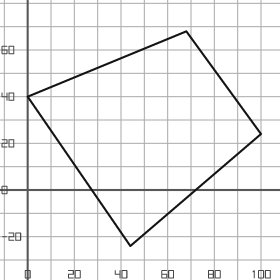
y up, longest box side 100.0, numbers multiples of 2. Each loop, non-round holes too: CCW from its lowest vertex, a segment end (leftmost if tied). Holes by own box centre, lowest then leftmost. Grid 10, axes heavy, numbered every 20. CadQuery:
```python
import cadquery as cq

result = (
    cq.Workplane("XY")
    .moveTo(44.0, -24.0)
    .lineTo(100.0, 24.0)
    .lineTo(68.0, 68.0)
    .lineTo(0.0, 40.0)
    .close()
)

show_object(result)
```